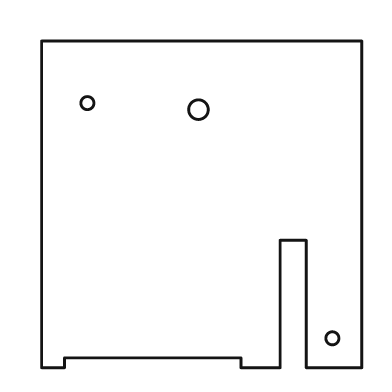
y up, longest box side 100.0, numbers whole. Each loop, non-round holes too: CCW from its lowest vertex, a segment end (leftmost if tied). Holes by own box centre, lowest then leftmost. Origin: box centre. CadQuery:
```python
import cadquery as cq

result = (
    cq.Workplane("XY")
    .moveTo(-49.0, -50.0)
    .lineTo(-42.0, -50.0)
    .lineTo(-42.0, -47.0)
    .lineTo(12.0, -47.0)
    .lineTo(12.0, -50.0)
    .lineTo(24.0, -50.0)
    .lineTo(24.0, -11.0)
    .lineTo(32.0, -11.0)
    .lineTo(32.0, -50.0)
    .lineTo(49.0, -50.0)
    .lineTo(49.0, 50.0)
    .lineTo(-49.0, 50.0)
    .close()
    .moveTo(40.0, -41.0)
    .circle(2.0)
    .moveTo(-1.0, 29.0)
    .circle(3.0)
    .moveTo(-35.0, 31.0)
    .circle(2.0)
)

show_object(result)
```